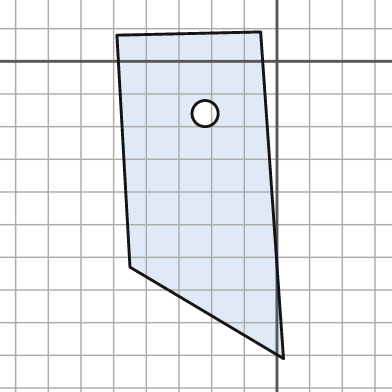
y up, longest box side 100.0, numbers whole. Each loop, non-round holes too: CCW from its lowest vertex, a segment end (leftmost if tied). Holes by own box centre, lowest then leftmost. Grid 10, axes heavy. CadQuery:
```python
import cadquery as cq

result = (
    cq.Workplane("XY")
    .moveTo(2.0, -91.0)
    .lineTo(-5.0, 9.0)
    .lineTo(-49.0, 8.0)
    .lineTo(-45.0, -63.0)
    .close()
    .moveTo(-22.0, -16.0)
    .circle(4.0)
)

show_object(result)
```